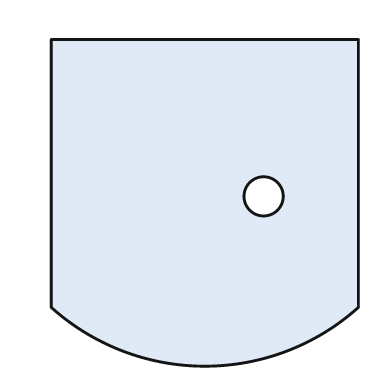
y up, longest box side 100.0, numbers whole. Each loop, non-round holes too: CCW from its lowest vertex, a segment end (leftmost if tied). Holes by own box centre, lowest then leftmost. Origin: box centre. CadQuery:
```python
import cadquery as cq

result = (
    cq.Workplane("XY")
    .moveTo(-47.0, -32.0)
    .threePointArc((0.0, -50.0), (47.0, -32.0))
    .lineTo(47.0, 50.0)
    .lineTo(-47.0, 50.0)
    .close()
    .moveTo(18.0, 2.0)
    .circle(6.0)
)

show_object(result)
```